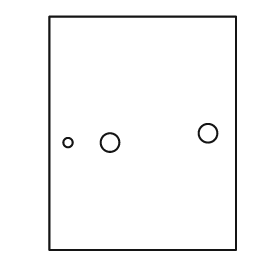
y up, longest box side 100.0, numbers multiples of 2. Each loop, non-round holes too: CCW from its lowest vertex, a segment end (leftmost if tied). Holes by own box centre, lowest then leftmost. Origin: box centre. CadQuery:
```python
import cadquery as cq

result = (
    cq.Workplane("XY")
    .moveTo(-40.0, -50.0)
    .lineTo(40.0, -50.0)
    .lineTo(40.0, 50.0)
    .lineTo(-40.0, 50.0)
    .close()
    .moveTo(-32.0, -4.0)
    .circle(2.0)
    .moveTo(-14.0, -4.0)
    .circle(4.0)
    .moveTo(28.0, 0.0)
    .circle(4.0)
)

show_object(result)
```